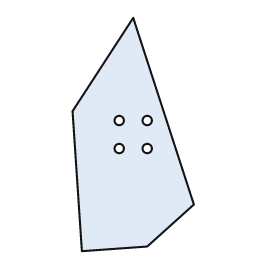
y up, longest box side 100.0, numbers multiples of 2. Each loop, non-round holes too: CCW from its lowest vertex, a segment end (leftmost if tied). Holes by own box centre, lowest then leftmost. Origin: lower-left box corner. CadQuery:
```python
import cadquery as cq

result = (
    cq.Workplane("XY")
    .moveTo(4.0, 0.0)
    .lineTo(32.0, 2.0)
    .lineTo(52.0, 20.0)
    .lineTo(26.0, 100.0)
    .lineTo(0.0, 60.0)
    .close()
    .moveTo(20.0, 44.0)
    .circle(2.0)
    .moveTo(32.0, 44.0)
    .circle(2.0)
    .moveTo(20.0, 56.0)
    .circle(2.0)
    .moveTo(32.0, 56.0)
    .circle(2.0)
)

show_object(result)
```